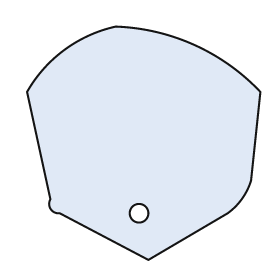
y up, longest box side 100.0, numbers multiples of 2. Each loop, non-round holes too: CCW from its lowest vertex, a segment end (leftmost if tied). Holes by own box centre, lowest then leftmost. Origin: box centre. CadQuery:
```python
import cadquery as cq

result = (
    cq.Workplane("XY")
    .moveTo(2.0, -50.0)
    .lineTo(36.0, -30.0)
    .threePointArc((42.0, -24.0), (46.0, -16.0))
    .lineTo(50.0, 22.0)
    .threePointArc((22.0, 42.0), (-12.0, 50.0))
    .threePointArc((-34.0, 40.0), (-50.0, 22.0))
    .lineTo(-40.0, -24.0)
    .threePointArc((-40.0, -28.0), (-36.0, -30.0))
    .close()
    .moveTo(-2.0, -30.0)
    .circle(4.0)
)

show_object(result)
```